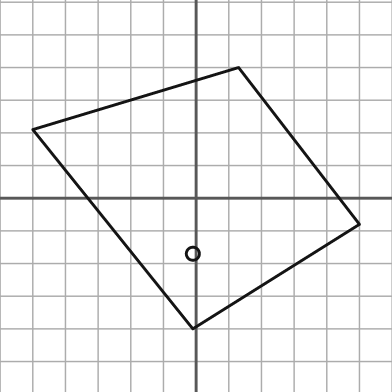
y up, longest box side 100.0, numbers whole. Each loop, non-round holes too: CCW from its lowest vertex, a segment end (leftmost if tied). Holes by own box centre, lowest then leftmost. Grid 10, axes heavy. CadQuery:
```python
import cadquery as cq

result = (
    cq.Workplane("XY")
    .moveTo(-1.0, -40.0)
    .lineTo(50.0, -8.0)
    .lineTo(13.0, 40.0)
    .lineTo(-50.0, 21.0)
    .close()
    .moveTo(-1.0, -17.0)
    .circle(2.0)
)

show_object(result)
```